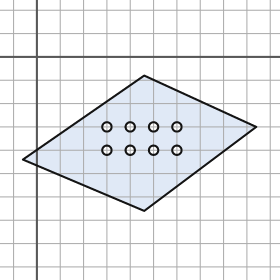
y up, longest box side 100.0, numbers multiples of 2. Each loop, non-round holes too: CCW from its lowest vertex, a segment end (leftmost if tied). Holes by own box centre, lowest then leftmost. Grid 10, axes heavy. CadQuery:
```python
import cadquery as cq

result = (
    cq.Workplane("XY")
    .moveTo(46.0, -66.0)
    .lineTo(94.0, -30.0)
    .lineTo(46.0, -8.0)
    .lineTo(-6.0, -44.0)
    .close()
    .moveTo(30.0, -40.0)
    .circle(2.0)
    .moveTo(40.0, -40.0)
    .circle(2.0)
    .moveTo(50.0, -40.0)
    .circle(2.0)
    .moveTo(60.0, -40.0)
    .circle(2.0)
    .moveTo(30.0, -30.0)
    .circle(2.0)
    .moveTo(40.0, -30.0)
    .circle(2.0)
    .moveTo(50.0, -30.0)
    .circle(2.0)
    .moveTo(60.0, -30.0)
    .circle(2.0)
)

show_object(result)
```